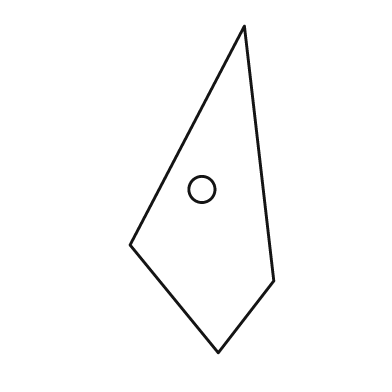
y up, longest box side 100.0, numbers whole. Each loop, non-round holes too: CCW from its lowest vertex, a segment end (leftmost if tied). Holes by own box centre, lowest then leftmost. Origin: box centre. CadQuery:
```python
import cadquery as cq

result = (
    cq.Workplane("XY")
    .moveTo(5.0, -50.0)
    .lineTo(22.0, -28.0)
    .lineTo(13.0, 50.0)
    .lineTo(-22.0, -17.0)
    .close()
    .moveTo(0.0, 0.0)
    .circle(4.0)
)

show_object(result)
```